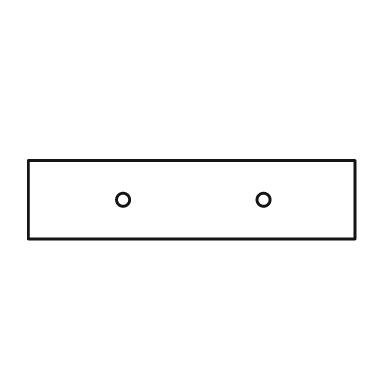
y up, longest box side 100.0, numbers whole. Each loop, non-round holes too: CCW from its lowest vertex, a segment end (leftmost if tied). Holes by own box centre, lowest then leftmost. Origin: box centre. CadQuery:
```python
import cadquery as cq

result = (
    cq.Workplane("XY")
    .moveTo(-50.0, -12.0)
    .lineTo(50.0, -12.0)
    .lineTo(50.0, 12.0)
    .lineTo(-50.0, 12.0)
    .close()
    .moveTo(-21.0, 0.0)
    .circle(2.0)
    .moveTo(22.0, 0.0)
    .circle(2.0)
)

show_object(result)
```